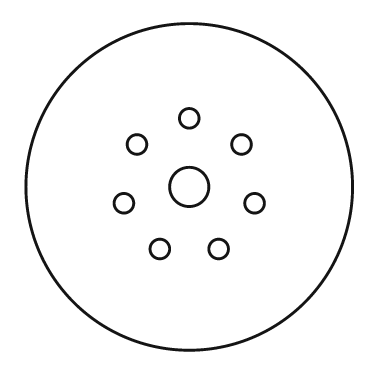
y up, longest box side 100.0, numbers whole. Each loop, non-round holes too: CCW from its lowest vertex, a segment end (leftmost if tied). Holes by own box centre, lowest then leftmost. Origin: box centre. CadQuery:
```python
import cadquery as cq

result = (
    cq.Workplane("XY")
    .moveTo(0.0, 0.0)
    .circle(50.0)
    .moveTo(-9.0, -19.0)
    .circle(3.0)
    .moveTo(9.0, -19.0)
    .circle(3.0)
    .moveTo(-20.0, -5.0)
    .circle(3.0)
    .moveTo(20.0, -5.0)
    .circle(3.0)
    .moveTo(0.0, 0.0)
    .circle(6.0)
    .moveTo(-16.0, 13.0)
    .circle(3.0)
    .moveTo(16.0, 13.0)
    .circle(3.0)
    .moveTo(0.0, 21.0)
    .circle(3.0)
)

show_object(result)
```